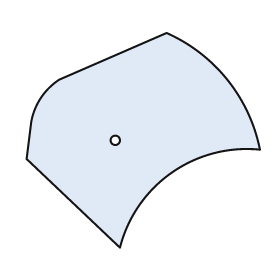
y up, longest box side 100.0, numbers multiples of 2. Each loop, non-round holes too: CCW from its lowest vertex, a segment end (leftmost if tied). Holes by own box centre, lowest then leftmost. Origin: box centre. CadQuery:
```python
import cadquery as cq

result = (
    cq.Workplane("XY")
    .moveTo(-10.0, -46.0)
    .threePointArc((12.0, -14.0), (50.0, -4.0))
    .threePointArc((36.0, 26.0), (10.0, 46.0))
    .lineTo(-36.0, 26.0)
    .threePointArc((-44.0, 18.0), (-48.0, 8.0))
    .lineTo(-50.0, -8.0)
    .close()
    .moveTo(-12.0, 0.0)
    .circle(2.0)
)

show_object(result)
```